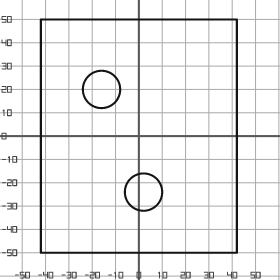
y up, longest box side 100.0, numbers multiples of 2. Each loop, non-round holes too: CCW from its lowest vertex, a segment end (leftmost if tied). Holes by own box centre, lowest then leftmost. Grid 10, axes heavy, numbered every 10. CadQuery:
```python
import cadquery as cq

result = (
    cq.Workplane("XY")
    .moveTo(-42.0, -50.0)
    .lineTo(42.0, -50.0)
    .lineTo(42.0, 50.0)
    .lineTo(-42.0, 50.0)
    .close()
    .moveTo(2.0, -24.0)
    .circle(8.0)
    .moveTo(-16.0, 20.0)
    .circle(8.0)
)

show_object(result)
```